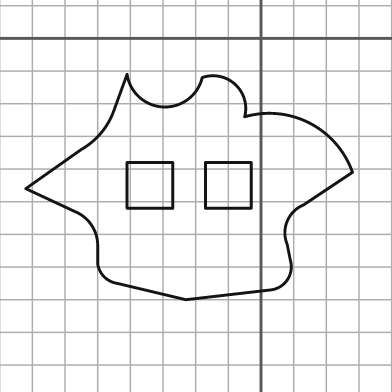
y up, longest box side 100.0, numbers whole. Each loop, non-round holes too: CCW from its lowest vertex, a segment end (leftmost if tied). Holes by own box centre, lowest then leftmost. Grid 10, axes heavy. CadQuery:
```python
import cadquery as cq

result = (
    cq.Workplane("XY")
    .moveTo(-23.0, -80.0)
    .lineTo(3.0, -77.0)
    .threePointArc((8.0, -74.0), (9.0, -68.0))
    .lineTo(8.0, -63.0)
    .threePointArc((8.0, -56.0), (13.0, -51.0))
    .lineTo(28.0, -41.0)
    .threePointArc((15.0, -26.0), (-5.0, -24.0))
    .threePointArc((-8.0, -14.0), (-18.0, -12.0))
    .threePointArc((-30.0, -21.0), (-41.0, -11.0))
    .lineTo(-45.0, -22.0)
    .threePointArc((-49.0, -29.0), (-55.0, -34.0))
    .lineTo(-72.0, -46.0)
    .lineTo(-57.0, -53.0)
    .threePointArc((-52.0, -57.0), (-50.0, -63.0))
    .lineTo(-50.0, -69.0)
    .threePointArc((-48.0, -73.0), (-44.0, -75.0))
    .close()
    .moveTo(-41.0, -52.0)
    .lineTo(-27.0, -52.0)
    .lineTo(-27.0, -38.0)
    .lineTo(-41.0, -38.0)
    .close()
    .moveTo(-17.0, -52.0)
    .lineTo(-3.0, -52.0)
    .lineTo(-3.0, -38.0)
    .lineTo(-17.0, -38.0)
    .close()
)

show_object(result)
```